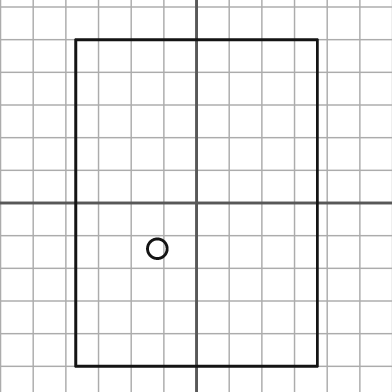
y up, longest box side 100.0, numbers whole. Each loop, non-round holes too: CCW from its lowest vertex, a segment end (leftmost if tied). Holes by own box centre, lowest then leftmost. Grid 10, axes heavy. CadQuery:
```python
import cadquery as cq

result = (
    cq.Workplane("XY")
    .moveTo(-37.0, -50.0)
    .lineTo(37.0, -50.0)
    .lineTo(37.0, 50.0)
    .lineTo(-37.0, 50.0)
    .close()
    .moveTo(-12.0, -14.0)
    .circle(3.0)
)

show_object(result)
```